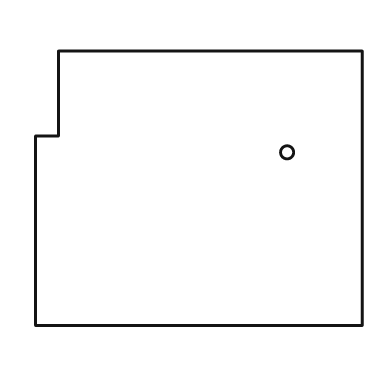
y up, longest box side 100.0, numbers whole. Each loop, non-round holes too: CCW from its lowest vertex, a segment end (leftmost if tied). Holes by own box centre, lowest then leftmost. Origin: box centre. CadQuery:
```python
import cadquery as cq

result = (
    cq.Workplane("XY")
    .moveTo(-50.0, -42.0)
    .lineTo(50.0, -42.0)
    .lineTo(50.0, 42.0)
    .lineTo(-43.0, 42.0)
    .lineTo(-43.0, 16.0)
    .lineTo(-50.0, 16.0)
    .close()
    .moveTo(27.0, 11.0)
    .circle(2.0)
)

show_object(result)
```